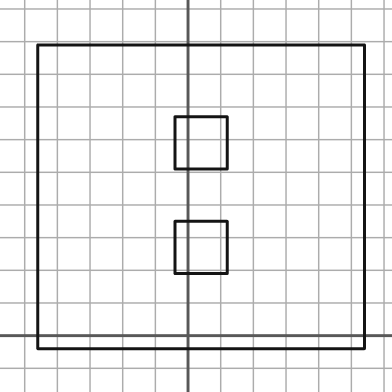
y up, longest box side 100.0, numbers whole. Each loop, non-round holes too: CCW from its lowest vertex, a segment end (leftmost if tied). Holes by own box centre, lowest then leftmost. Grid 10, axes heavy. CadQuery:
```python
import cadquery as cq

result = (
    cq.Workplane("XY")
    .moveTo(-46.0, -4.0)
    .lineTo(54.0, -4.0)
    .lineTo(54.0, 89.0)
    .lineTo(-46.0, 89.0)
    .close()
    .moveTo(-4.0, 19.0)
    .lineTo(12.0, 19.0)
    .lineTo(12.0, 35.0)
    .lineTo(-4.0, 35.0)
    .close()
    .moveTo(-4.0, 51.0)
    .lineTo(12.0, 51.0)
    .lineTo(12.0, 67.0)
    .lineTo(-4.0, 67.0)
    .close()
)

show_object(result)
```